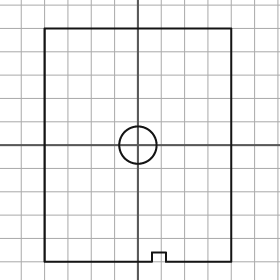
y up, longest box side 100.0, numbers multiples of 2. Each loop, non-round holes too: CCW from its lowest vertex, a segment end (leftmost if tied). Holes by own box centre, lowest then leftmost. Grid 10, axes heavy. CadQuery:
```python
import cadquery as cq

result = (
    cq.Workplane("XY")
    .moveTo(-40.0, -50.0)
    .lineTo(6.0, -50.0)
    .lineTo(6.0, -46.0)
    .lineTo(12.0, -46.0)
    .lineTo(12.0, -50.0)
    .lineTo(40.0, -50.0)
    .lineTo(40.0, 50.0)
    .lineTo(-40.0, 50.0)
    .close()
    .moveTo(0.0, 0.0)
    .circle(8.0)
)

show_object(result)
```